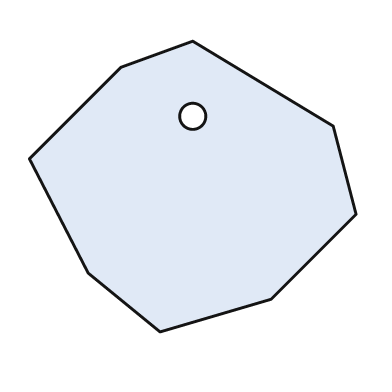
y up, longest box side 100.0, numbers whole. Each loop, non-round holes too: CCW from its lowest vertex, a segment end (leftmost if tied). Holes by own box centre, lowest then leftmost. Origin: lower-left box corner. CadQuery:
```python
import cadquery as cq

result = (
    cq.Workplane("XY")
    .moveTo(40.0, 0.0)
    .lineTo(74.0, 10.0)
    .lineTo(100.0, 36.0)
    .lineTo(93.0, 63.0)
    .lineTo(50.0, 89.0)
    .lineTo(28.0, 81.0)
    .lineTo(0.0, 53.0)
    .lineTo(18.0, 18.0)
    .close()
    .moveTo(50.0, 66.0)
    .circle(4.0)
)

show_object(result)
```